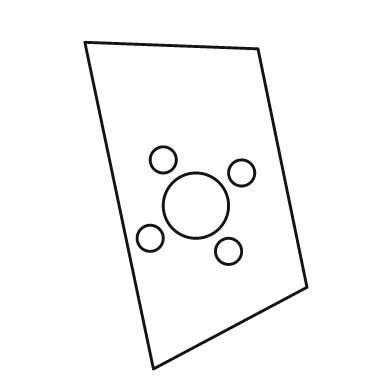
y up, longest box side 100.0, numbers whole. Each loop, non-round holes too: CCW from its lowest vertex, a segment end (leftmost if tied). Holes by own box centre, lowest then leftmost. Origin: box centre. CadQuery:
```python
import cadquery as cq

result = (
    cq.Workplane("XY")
    .moveTo(-13.0, -50.0)
    .lineTo(34.0, -25.0)
    .lineTo(19.0, 48.0)
    .lineTo(-34.0, 50.0)
    .close()
    .moveTo(10.0, -14.0)
    .circle(4.0)
    .moveTo(-14.0, -10.0)
    .circle(4.0)
    .moveTo(0.0, 0.0)
    .circle(10.0)
    .moveTo(14.0, 10.0)
    .circle(4.0)
    .moveTo(-10.0, 14.0)
    .circle(4.0)
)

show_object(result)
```